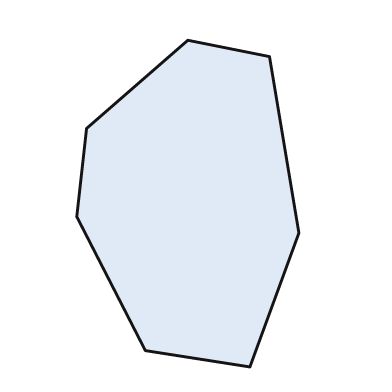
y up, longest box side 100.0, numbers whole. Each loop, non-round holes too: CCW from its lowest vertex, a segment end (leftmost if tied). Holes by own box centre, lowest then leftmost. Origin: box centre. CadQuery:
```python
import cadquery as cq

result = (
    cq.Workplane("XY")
    .moveTo(19.0, -50.0)
    .lineTo(34.0, -9.0)
    .lineTo(25.0, 45.0)
    .lineTo(0.0, 50.0)
    .lineTo(-31.0, 23.0)
    .lineTo(-34.0, -4.0)
    .lineTo(-13.0, -45.0)
    .close()
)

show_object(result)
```